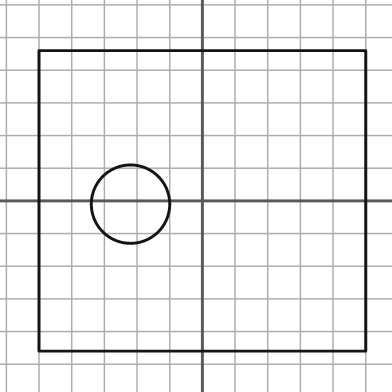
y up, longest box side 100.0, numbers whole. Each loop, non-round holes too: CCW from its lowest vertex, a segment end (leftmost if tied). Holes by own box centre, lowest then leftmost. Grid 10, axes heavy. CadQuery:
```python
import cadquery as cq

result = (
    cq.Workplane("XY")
    .moveTo(-50.0, -46.0)
    .lineTo(50.0, -46.0)
    .lineTo(50.0, 46.0)
    .lineTo(-50.0, 46.0)
    .close()
    .moveTo(-22.0, -1.0)
    .circle(12.0)
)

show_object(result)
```